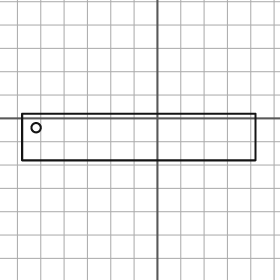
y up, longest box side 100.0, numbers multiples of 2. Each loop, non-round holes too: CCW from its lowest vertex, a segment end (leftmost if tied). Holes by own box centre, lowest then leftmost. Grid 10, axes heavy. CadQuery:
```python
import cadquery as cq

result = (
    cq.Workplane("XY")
    .moveTo(-58.0, -18.0)
    .lineTo(42.0, -18.0)
    .lineTo(42.0, 2.0)
    .lineTo(-58.0, 2.0)
    .close()
    .moveTo(-52.0, -4.0)
    .circle(2.0)
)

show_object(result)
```